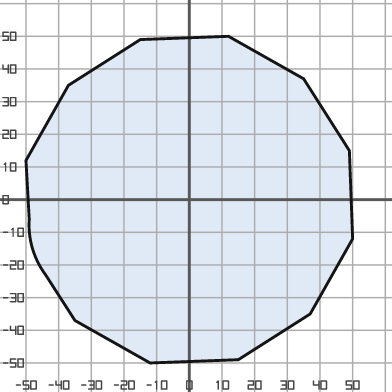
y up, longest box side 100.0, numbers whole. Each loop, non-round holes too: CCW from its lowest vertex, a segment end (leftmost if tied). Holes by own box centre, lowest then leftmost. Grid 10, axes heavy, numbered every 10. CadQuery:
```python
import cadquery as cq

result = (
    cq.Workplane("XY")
    .moveTo(-12.0, -50.0)
    .lineTo(15.0, -49.0)
    .lineTo(37.0, -35.0)
    .lineTo(50.0, -12.0)
    .lineTo(49.0, 15.0)
    .lineTo(35.0, 37.0)
    .lineTo(12.0, 50.0)
    .lineTo(-15.0, 49.0)
    .lineTo(-37.0, 35.0)
    .lineTo(-50.0, 12.0)
    .lineTo(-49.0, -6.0)
    .threePointArc((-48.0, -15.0), (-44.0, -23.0))
    .lineTo(-35.0, -37.0)
    .close()
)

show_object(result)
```